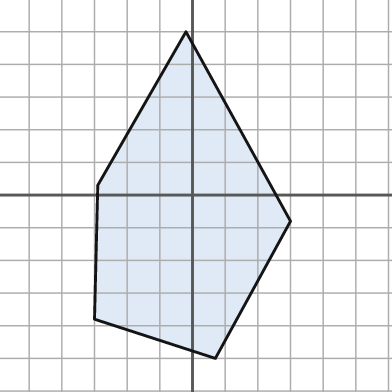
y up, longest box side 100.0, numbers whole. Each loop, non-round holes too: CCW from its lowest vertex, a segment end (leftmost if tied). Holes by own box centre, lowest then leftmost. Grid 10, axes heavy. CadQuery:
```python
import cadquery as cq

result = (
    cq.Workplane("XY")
    .moveTo(7.0, -50.0)
    .lineTo(30.0, -8.0)
    .lineTo(-2.0, 50.0)
    .lineTo(-29.0, 3.0)
    .lineTo(-30.0, -38.0)
    .close()
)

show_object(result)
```